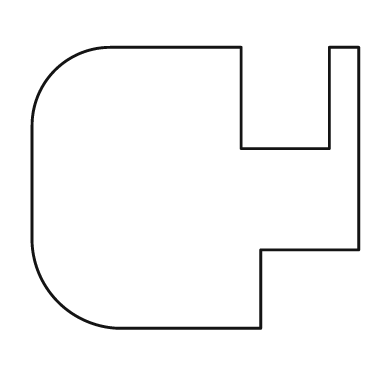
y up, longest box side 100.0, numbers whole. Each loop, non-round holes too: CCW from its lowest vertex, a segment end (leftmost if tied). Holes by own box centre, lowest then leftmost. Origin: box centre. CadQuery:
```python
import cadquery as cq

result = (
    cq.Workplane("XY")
    .moveTo(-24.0, -43.0)
    .lineTo(20.0, -43.0)
    .lineTo(20.0, -19.0)
    .lineTo(50.0, -19.0)
    .lineTo(50.0, 43.0)
    .lineTo(41.0, 43.0)
    .lineTo(41.0, 12.0)
    .lineTo(14.0, 12.0)
    .lineTo(14.0, 43.0)
    .lineTo(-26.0, 43.0)
    .threePointArc((-43.0, 36.0), (-50.0, 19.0))
    .lineTo(-50.0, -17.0)
    .threePointArc((-42.0, -35.0), (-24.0, -43.0))
    .close()
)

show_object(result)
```